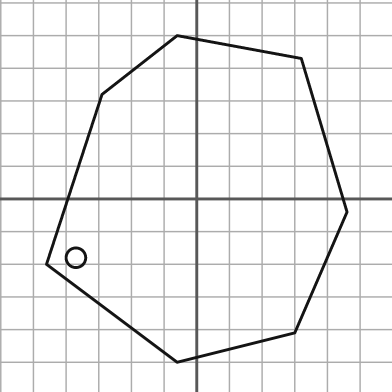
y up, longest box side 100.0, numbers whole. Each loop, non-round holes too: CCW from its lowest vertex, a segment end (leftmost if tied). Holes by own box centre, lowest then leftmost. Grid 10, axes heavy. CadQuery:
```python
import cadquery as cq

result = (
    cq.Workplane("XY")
    .moveTo(-6.0, -50.0)
    .lineTo(30.0, -41.0)
    .lineTo(46.0, -4.0)
    .lineTo(32.0, 43.0)
    .lineTo(-6.0, 50.0)
    .lineTo(-29.0, 32.0)
    .lineTo(-46.0, -20.0)
    .close()
    .moveTo(-37.0, -18.0)
    .circle(3.0)
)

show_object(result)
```